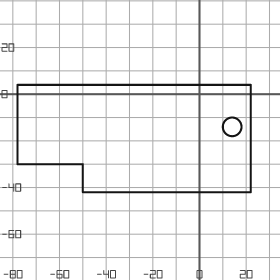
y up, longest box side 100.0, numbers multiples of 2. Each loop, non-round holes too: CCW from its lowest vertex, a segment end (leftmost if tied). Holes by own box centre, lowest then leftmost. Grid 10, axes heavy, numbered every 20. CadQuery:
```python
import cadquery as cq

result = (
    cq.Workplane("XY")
    .moveTo(-50.0, -42.0)
    .lineTo(22.0, -42.0)
    .lineTo(22.0, 4.0)
    .lineTo(-78.0, 4.0)
    .lineTo(-78.0, -30.0)
    .lineTo(-50.0, -30.0)
    .close()
    .moveTo(14.0, -14.0)
    .circle(4.0)
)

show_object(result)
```